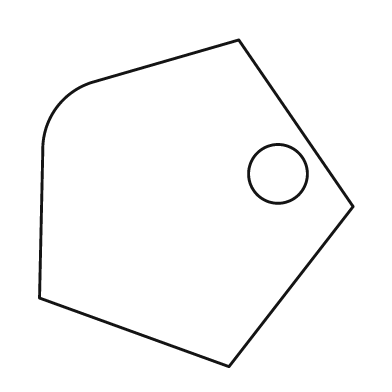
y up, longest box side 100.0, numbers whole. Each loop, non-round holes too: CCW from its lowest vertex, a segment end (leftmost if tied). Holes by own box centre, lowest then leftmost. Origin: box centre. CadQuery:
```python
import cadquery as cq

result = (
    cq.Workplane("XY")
    .moveTo(10.0, -50.0)
    .lineTo(48.0, -1.0)
    .lineTo(13.0, 50.0)
    .lineTo(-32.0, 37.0)
    .threePointArc((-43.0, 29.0), (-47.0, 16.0))
    .lineTo(-48.0, -29.0)
    .close()
    .moveTo(25.0, 9.0)
    .circle(9.0)
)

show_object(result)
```